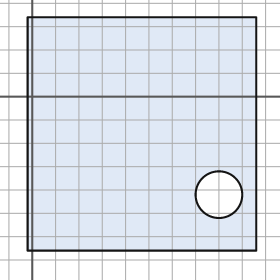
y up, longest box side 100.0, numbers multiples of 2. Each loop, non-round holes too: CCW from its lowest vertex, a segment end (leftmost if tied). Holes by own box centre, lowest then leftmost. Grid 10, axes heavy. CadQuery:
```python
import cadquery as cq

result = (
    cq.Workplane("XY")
    .moveTo(-2.0, -66.0)
    .lineTo(96.0, -66.0)
    .lineTo(96.0, 34.0)
    .lineTo(-2.0, 34.0)
    .close()
    .moveTo(80.0, -42.0)
    .circle(10.0)
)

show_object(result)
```